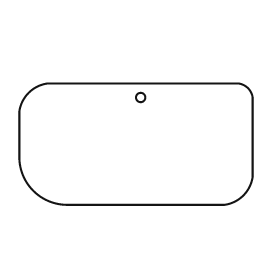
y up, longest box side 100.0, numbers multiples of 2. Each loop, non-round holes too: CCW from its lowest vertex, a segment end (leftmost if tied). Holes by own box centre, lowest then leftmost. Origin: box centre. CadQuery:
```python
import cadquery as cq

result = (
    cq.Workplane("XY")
    .moveTo(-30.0, -26.0)
    .lineTo(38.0, -26.0)
    .threePointArc((46.0, -22.0), (50.0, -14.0))
    .lineTo(50.0, 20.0)
    .threePointArc((48.0, 24.0), (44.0, 26.0))
    .lineTo(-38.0, 26.0)
    .threePointArc((-46.0, 22.0), (-50.0, 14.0))
    .lineTo(-50.0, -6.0)
    .threePointArc((-44.0, -20.0), (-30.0, -26.0))
    .close()
    .moveTo(2.0, 20.0)
    .circle(2.0)
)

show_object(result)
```